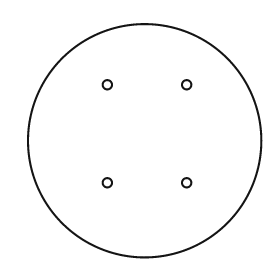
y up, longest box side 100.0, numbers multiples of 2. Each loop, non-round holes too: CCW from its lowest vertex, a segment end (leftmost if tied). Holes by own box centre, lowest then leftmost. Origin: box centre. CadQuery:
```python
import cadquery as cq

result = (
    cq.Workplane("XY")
    .moveTo(0.0, 0.0)
    .circle(50.0)
    .moveTo(-16.0, -18.0)
    .circle(2.0)
    .moveTo(18.0, -18.0)
    .circle(2.0)
    .moveTo(-16.0, 24.0)
    .circle(2.0)
    .moveTo(18.0, 24.0)
    .circle(2.0)
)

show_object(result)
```